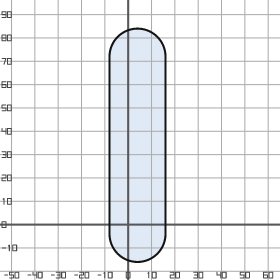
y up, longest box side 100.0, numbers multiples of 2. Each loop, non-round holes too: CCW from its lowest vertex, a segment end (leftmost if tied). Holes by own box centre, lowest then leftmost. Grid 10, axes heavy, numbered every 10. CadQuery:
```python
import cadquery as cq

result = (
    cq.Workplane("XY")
    .moveTo(-8.0, -4.0)
    .threePointArc((4.0, -16.0), (16.0, -4.0))
    .lineTo(16.0, 72.0)
    .threePointArc((4.0, 84.0), (-8.0, 72.0))
    .close()
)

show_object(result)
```